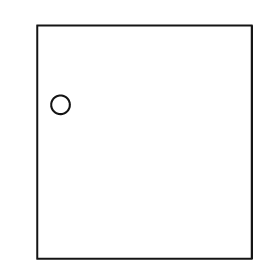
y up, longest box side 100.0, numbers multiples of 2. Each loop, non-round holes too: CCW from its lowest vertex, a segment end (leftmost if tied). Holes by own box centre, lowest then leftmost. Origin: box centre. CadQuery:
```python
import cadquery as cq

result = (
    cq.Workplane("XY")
    .moveTo(-46.0, -50.0)
    .lineTo(46.0, -50.0)
    .lineTo(46.0, 50.0)
    .lineTo(-46.0, 50.0)
    .close()
    .moveTo(-36.0, 16.0)
    .circle(4.0)
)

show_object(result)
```